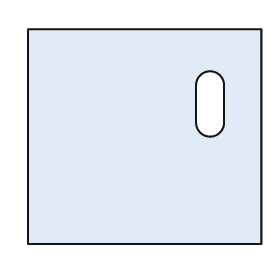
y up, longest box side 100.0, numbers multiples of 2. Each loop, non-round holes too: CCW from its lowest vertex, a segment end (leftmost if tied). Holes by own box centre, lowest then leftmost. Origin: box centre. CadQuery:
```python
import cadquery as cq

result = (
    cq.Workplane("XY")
    .moveTo(-50.0, -46.0)
    .lineTo(50.0, -46.0)
    .lineTo(50.0, 46.0)
    .lineTo(-50.0, 46.0)
    .close()
    .moveTo(22.0, 6.0)
    .threePointArc((28.0, 0.0), (34.0, 6.0))
    .lineTo(34.0, 22.0)
    .threePointArc((28.0, 28.0), (22.0, 22.0))
    .close()
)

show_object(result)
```